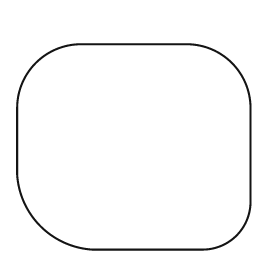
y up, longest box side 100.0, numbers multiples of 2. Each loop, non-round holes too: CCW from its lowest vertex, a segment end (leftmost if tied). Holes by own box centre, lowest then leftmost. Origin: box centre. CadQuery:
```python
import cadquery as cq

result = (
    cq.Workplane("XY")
    .moveTo(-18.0, -44.0)
    .lineTo(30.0, -44.0)
    .threePointArc((44.0, -38.0), (50.0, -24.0))
    .lineTo(50.0, 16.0)
    .threePointArc((42.0, 36.0), (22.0, 44.0))
    .lineTo(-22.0, 44.0)
    .threePointArc((-42.0, 36.0), (-50.0, 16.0))
    .lineTo(-50.0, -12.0)
    .threePointArc((-40.0, -34.0), (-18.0, -44.0))
    .close()
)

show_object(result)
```